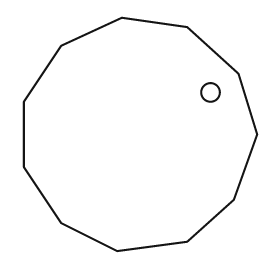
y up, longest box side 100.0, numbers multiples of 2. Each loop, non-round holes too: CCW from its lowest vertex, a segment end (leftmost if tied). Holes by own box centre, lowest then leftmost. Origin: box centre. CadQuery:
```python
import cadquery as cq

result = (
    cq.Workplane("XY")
    .moveTo(-10.0, -50.0)
    .lineTo(20.0, -46.0)
    .lineTo(40.0, -28.0)
    .lineTo(50.0, 0.0)
    .lineTo(42.0, 26.0)
    .lineTo(20.0, 46.0)
    .lineTo(-8.0, 50.0)
    .lineTo(-34.0, 38.0)
    .lineTo(-50.0, 14.0)
    .lineTo(-50.0, -14.0)
    .lineTo(-34.0, -38.0)
    .close()
    .moveTo(30.0, 18.0)
    .circle(4.0)
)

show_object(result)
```